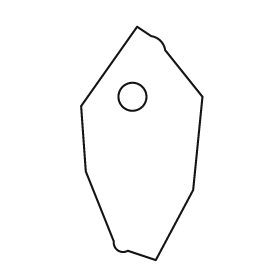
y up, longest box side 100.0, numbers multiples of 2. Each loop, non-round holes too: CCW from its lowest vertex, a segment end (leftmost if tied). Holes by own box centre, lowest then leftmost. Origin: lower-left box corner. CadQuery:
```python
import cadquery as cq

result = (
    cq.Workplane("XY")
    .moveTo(32.0, 0.0)
    .lineTo(48.0, 30.0)
    .lineTo(52.0, 70.0)
    .lineTo(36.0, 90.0)
    .threePointArc((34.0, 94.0), (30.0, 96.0))
    .lineTo(24.0, 100.0)
    .lineTo(0.0, 66.0)
    .lineTo(2.0, 38.0)
    .lineTo(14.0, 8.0)
    .threePointArc((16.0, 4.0), (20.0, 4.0))
    .close()
    .moveTo(22.0, 70.0)
    .circle(6.0)
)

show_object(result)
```